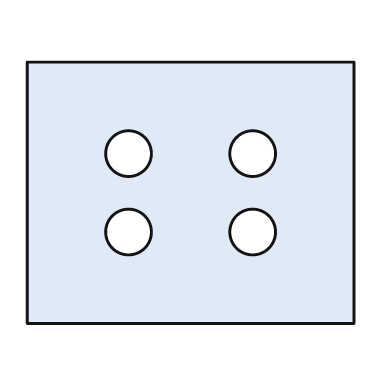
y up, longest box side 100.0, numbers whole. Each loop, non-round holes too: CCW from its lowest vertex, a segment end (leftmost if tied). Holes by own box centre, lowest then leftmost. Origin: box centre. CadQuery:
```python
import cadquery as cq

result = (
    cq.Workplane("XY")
    .moveTo(-50.0, -40.0)
    .lineTo(50.0, -40.0)
    .lineTo(50.0, 40.0)
    .lineTo(-50.0, 40.0)
    .close()
    .moveTo(-19.0, -12.0)
    .circle(7.0)
    .moveTo(19.0, -12.0)
    .circle(7.0)
    .moveTo(-19.0, 12.0)
    .circle(7.0)
    .moveTo(19.0, 12.0)
    .circle(7.0)
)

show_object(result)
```